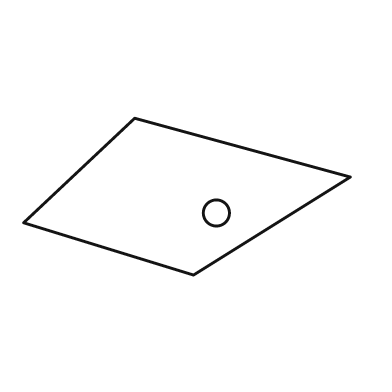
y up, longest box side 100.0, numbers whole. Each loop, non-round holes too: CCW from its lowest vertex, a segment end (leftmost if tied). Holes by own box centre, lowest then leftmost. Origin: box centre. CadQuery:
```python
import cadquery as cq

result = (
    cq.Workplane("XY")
    .moveTo(2.0, -24.0)
    .lineTo(50.0, 6.0)
    .lineTo(-16.0, 24.0)
    .lineTo(-50.0, -8.0)
    .close()
    .moveTo(9.0, -5.0)
    .circle(4.0)
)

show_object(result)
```